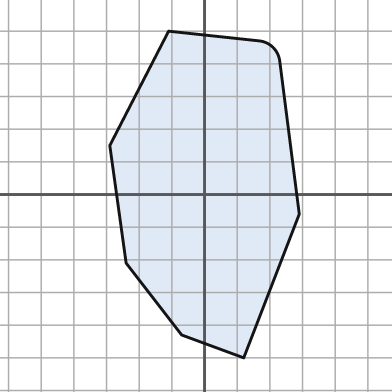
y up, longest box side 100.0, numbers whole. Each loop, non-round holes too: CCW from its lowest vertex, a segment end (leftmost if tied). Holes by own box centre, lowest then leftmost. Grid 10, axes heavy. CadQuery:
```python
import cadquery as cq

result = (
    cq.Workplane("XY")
    .moveTo(12.0, -50.0)
    .lineTo(29.0, -6.0)
    .lineTo(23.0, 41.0)
    .threePointArc((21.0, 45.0), (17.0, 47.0))
    .lineTo(-11.0, 50.0)
    .lineTo(-29.0, 15.0)
    .lineTo(-24.0, -21.0)
    .lineTo(-7.0, -43.0)
    .close()
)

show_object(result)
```